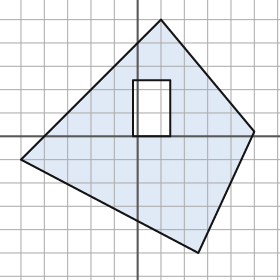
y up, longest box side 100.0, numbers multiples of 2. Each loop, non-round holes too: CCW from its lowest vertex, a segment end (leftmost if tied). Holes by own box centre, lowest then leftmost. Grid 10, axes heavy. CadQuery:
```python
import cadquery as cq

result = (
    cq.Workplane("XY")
    .moveTo(26.0, -50.0)
    .lineTo(50.0, 2.0)
    .lineTo(10.0, 50.0)
    .lineTo(-50.0, -10.0)
    .close()
    .moveTo(-2.0, 0.0)
    .lineTo(14.0, 0.0)
    .lineTo(14.0, 24.0)
    .lineTo(-2.0, 24.0)
    .close()
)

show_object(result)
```